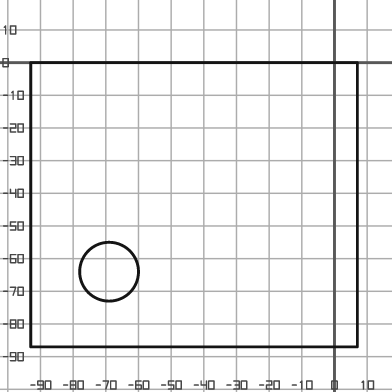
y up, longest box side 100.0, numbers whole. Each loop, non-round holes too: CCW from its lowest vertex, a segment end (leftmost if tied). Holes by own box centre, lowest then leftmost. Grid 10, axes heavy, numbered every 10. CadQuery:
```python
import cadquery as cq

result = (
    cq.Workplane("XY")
    .moveTo(-93.0, -87.0)
    .lineTo(7.0, -87.0)
    .lineTo(7.0, 0.0)
    .lineTo(-93.0, 0.0)
    .close()
    .moveTo(-69.0, -64.0)
    .circle(9.0)
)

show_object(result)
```